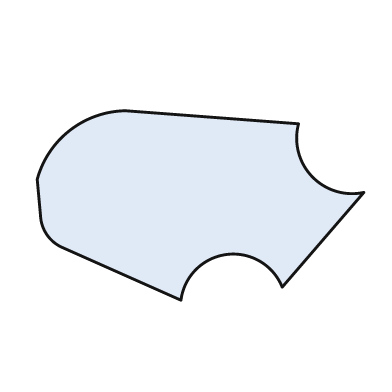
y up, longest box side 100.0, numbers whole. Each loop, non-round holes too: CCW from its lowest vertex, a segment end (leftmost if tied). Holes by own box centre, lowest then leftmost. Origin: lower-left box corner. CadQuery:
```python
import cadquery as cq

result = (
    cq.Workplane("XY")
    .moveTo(44.0, 0.0)
    .threePointArc((58.0, 14.0), (75.0, 4.0))
    .lineTo(100.0, 33.0)
    .threePointArc((84.0, 38.0), (80.0, 54.0))
    .lineTo(27.0, 58.0)
    .threePointArc((10.0, 52.0), (0.0, 37.0))
    .lineTo(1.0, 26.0)
    .threePointArc((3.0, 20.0), (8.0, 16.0))
    .close()
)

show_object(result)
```